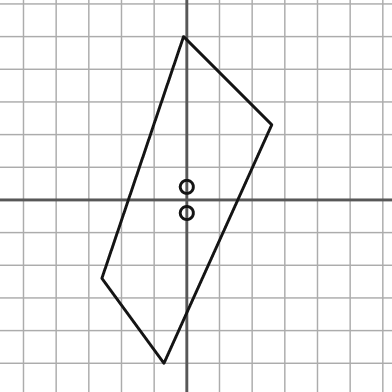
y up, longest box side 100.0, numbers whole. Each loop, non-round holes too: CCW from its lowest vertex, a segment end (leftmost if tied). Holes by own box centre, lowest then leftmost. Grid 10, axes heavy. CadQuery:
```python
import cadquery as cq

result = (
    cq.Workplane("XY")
    .moveTo(-7.0, -50.0)
    .lineTo(26.0, 23.0)
    .lineTo(-1.0, 50.0)
    .lineTo(-26.0, -24.0)
    .close()
    .moveTo(0.0, -4.0)
    .circle(2.0)
    .moveTo(0.0, 4.0)
    .circle(2.0)
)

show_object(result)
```